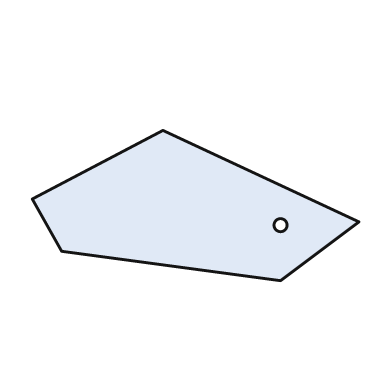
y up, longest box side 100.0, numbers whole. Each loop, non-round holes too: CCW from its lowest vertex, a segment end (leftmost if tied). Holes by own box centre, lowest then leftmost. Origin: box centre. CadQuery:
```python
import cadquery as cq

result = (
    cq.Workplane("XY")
    .moveTo(26.0, -23.0)
    .lineTo(50.0, -5.0)
    .lineTo(-10.0, 23.0)
    .lineTo(-50.0, 2.0)
    .lineTo(-41.0, -14.0)
    .close()
    .moveTo(26.0, -6.0)
    .circle(2.0)
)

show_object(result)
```